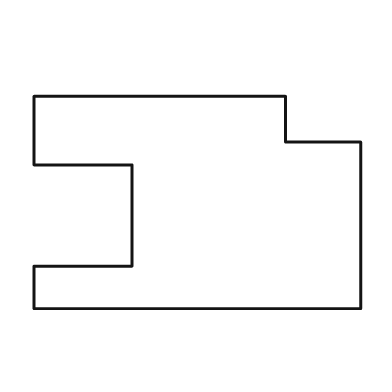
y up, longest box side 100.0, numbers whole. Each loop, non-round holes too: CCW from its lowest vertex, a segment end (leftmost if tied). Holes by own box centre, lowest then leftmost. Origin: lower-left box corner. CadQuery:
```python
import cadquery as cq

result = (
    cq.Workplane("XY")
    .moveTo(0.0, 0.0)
    .lineTo(100.0, 0.0)
    .lineTo(100.0, 51.0)
    .lineTo(77.0, 51.0)
    .lineTo(77.0, 65.0)
    .lineTo(0.0, 65.0)
    .lineTo(0.0, 44.0)
    .lineTo(30.0, 44.0)
    .lineTo(30.0, 13.0)
    .lineTo(0.0, 13.0)
    .close()
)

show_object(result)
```